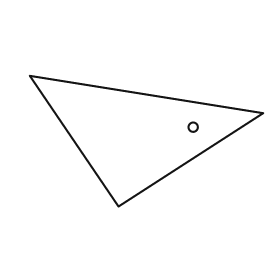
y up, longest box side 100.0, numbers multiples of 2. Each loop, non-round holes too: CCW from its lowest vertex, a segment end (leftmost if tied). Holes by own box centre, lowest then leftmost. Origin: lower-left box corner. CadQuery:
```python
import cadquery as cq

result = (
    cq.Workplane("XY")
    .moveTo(38.0, 0.0)
    .lineTo(100.0, 40.0)
    .lineTo(0.0, 56.0)
    .close()
    .moveTo(70.0, 34.0)
    .circle(2.0)
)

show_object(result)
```